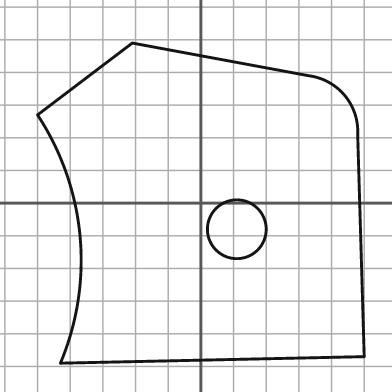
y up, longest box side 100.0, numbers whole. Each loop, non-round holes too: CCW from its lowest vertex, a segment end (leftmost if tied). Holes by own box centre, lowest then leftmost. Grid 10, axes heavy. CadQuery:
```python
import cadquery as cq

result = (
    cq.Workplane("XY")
    .moveTo(-43.0, -49.0)
    .lineTo(50.0, -47.0)
    .lineTo(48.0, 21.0)
    .threePointArc((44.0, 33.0), (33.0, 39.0))
    .lineTo(-21.0, 49.0)
    .lineTo(-50.0, 27.0)
    .threePointArc((-37.0, -10.0), (-43.0, -49.0))
    .close()
    .moveTo(11.0, -8.0)
    .circle(9.0)
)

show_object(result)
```